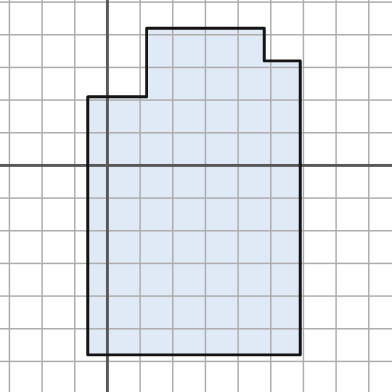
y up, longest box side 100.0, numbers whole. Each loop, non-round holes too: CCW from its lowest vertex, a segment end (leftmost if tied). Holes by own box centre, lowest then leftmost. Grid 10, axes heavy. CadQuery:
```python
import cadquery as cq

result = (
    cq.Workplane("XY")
    .moveTo(-6.0, -58.0)
    .lineTo(59.0, -58.0)
    .lineTo(59.0, 32.0)
    .lineTo(48.0, 32.0)
    .lineTo(48.0, 42.0)
    .lineTo(12.0, 42.0)
    .lineTo(12.0, 21.0)
    .lineTo(-6.0, 21.0)
    .close()
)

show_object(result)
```